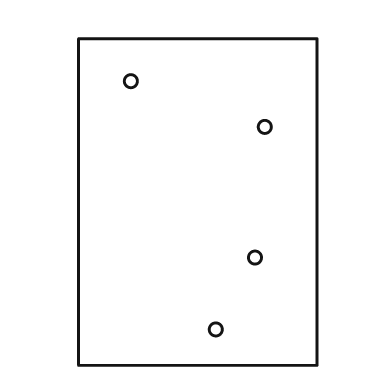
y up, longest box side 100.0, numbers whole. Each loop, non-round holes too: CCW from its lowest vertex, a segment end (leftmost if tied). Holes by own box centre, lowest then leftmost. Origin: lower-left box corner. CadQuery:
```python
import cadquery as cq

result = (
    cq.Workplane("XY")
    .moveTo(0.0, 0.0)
    .lineTo(73.0, 0.0)
    .lineTo(73.0, 100.0)
    .lineTo(0.0, 100.0)
    .close()
    .moveTo(42.0, 11.0)
    .circle(2.0)
    .moveTo(54.0, 33.0)
    .circle(2.0)
    .moveTo(57.0, 73.0)
    .circle(2.0)
    .moveTo(16.0, 87.0)
    .circle(2.0)
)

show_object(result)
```